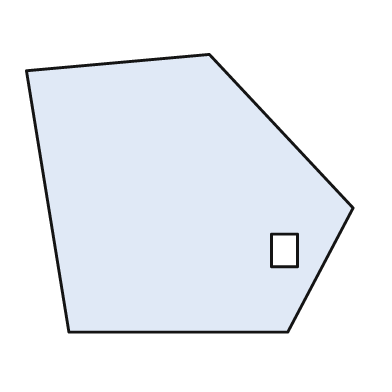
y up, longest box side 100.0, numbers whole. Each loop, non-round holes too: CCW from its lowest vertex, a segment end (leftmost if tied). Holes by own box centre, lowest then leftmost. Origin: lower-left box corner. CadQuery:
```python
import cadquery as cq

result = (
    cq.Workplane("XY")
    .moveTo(13.0, 0.0)
    .lineTo(80.0, 0.0)
    .lineTo(100.0, 38.0)
    .lineTo(56.0, 85.0)
    .lineTo(0.0, 80.0)
    .close()
    .moveTo(75.0, 20.0)
    .lineTo(83.0, 20.0)
    .lineTo(83.0, 30.0)
    .lineTo(75.0, 30.0)
    .close()
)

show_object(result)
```